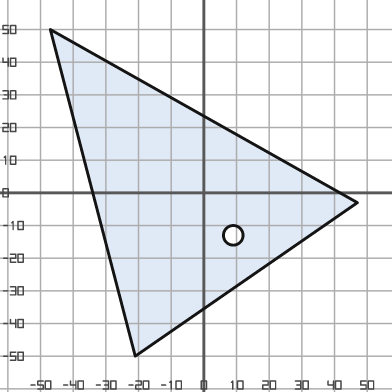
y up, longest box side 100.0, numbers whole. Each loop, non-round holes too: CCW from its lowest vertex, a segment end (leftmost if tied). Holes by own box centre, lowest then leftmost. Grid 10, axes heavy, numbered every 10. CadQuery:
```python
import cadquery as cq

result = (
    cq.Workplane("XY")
    .moveTo(-21.0, -50.0)
    .lineTo(47.0, -3.0)
    .lineTo(-47.0, 50.0)
    .close()
    .moveTo(9.0, -13.0)
    .circle(3.0)
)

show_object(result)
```